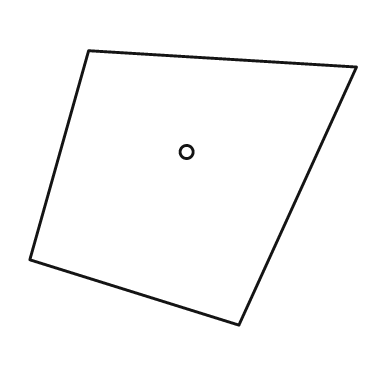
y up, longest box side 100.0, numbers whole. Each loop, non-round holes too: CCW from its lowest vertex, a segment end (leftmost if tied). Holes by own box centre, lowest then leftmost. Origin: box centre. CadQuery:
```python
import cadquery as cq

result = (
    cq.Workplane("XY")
    .moveTo(14.0, -42.0)
    .lineTo(50.0, 37.0)
    .lineTo(-32.0, 42.0)
    .lineTo(-50.0, -22.0)
    .close()
    .moveTo(-2.0, 11.0)
    .circle(2.0)
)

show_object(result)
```